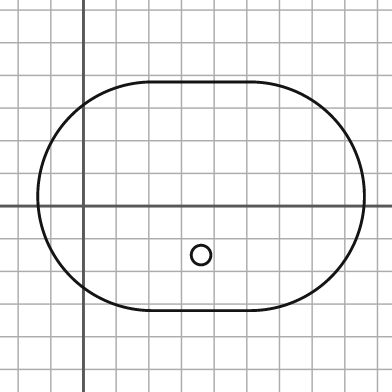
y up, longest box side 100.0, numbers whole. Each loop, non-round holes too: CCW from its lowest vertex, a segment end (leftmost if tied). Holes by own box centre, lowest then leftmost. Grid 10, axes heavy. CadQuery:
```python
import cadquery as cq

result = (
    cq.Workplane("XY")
    .moveTo(21.0, -32.0)
    .lineTo(51.0, -32.0)
    .threePointArc((86.0, 3.0), (51.0, 38.0))
    .lineTo(21.0, 38.0)
    .threePointArc((-14.0, 3.0), (21.0, -32.0))
    .close()
    .moveTo(36.0, -15.0)
    .circle(3.0)
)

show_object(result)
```